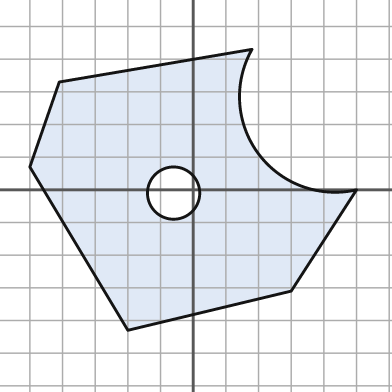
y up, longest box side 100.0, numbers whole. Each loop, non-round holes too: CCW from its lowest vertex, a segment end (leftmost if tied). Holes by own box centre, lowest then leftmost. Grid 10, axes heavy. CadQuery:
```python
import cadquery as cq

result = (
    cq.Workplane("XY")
    .moveTo(-20.0, -43.0)
    .lineTo(30.0, -31.0)
    .lineTo(50.0, 0.0)
    .threePointArc((20.0, 11.0), (18.0, 43.0))
    .lineTo(-41.0, 33.0)
    .lineTo(-50.0, 7.0)
    .close()
    .moveTo(-6.0, -1.0)
    .circle(8.0)
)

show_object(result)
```